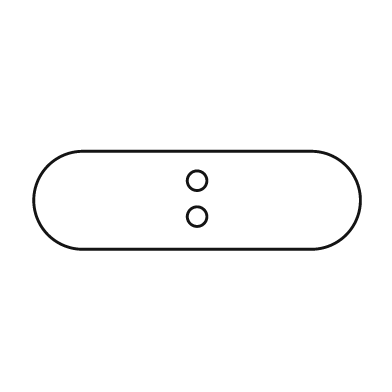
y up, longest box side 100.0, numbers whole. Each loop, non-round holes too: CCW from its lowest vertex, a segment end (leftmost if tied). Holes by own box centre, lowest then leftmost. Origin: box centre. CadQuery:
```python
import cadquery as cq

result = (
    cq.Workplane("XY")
    .moveTo(-35.0, -15.0)
    .lineTo(35.0, -15.0)
    .threePointArc((50.0, 0.0), (35.0, 15.0))
    .lineTo(-35.0, 15.0)
    .threePointArc((-50.0, 0.0), (-35.0, -15.0))
    .close()
    .moveTo(0.0, -5.0)
    .circle(3.0)
    .moveTo(0.0, 6.0)
    .circle(3.0)
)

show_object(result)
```